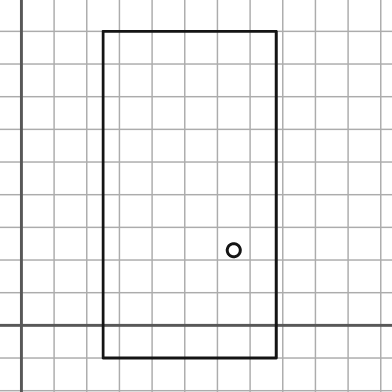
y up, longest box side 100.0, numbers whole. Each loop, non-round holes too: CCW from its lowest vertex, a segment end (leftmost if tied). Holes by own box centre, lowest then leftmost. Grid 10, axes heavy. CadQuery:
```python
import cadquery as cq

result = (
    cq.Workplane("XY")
    .moveTo(25.0, -10.0)
    .lineTo(78.0, -10.0)
    .lineTo(78.0, 90.0)
    .lineTo(25.0, 90.0)
    .close()
    .moveTo(65.0, 23.0)
    .circle(2.0)
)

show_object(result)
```